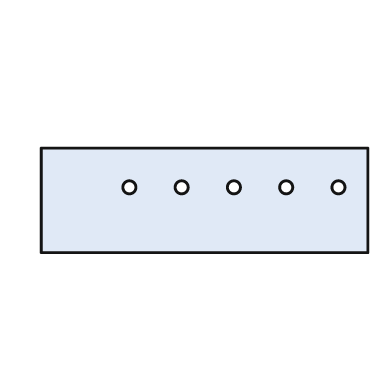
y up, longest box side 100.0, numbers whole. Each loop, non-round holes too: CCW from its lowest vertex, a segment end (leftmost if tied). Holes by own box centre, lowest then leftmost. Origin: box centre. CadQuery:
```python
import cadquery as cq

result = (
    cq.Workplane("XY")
    .moveTo(-50.0, -16.0)
    .lineTo(50.0, -16.0)
    .lineTo(50.0, 16.0)
    .lineTo(-50.0, 16.0)
    .close()
    .moveTo(-23.0, 4.0)
    .circle(2.0)
    .moveTo(-7.0, 4.0)
    .circle(2.0)
    .moveTo(9.0, 4.0)
    .circle(2.0)
    .moveTo(25.0, 4.0)
    .circle(2.0)
    .moveTo(41.0, 4.0)
    .circle(2.0)
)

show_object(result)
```